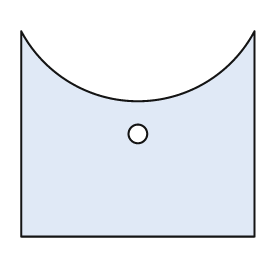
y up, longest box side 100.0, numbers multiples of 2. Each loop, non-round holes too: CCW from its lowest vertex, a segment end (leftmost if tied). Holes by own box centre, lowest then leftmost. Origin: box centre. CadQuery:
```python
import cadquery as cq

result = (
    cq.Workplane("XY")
    .moveTo(-50.0, -44.0)
    .lineTo(50.0, -44.0)
    .lineTo(50.0, 44.0)
    .threePointArc((0.0, 14.0), (-50.0, 44.0))
    .close()
    .moveTo(0.0, 0.0)
    .circle(4.0)
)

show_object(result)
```